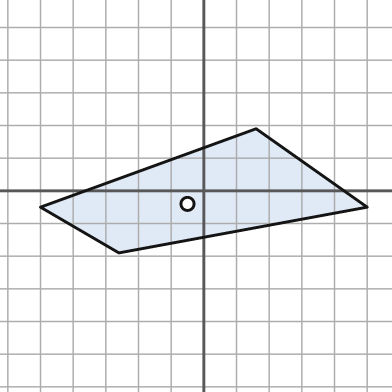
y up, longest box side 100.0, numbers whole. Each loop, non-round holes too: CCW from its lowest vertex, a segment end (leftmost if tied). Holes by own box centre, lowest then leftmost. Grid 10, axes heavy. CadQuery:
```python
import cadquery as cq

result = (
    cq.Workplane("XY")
    .moveTo(-26.0, -19.0)
    .lineTo(50.0, -5.0)
    .lineTo(16.0, 19.0)
    .lineTo(-50.0, -5.0)
    .close()
    .moveTo(-5.0, -4.0)
    .circle(2.0)
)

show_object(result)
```